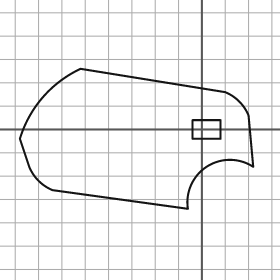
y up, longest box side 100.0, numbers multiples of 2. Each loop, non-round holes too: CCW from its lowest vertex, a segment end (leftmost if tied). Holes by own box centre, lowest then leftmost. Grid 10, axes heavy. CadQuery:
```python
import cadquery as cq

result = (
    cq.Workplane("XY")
    .moveTo(-6.0, -34.0)
    .threePointArc((2.0, -16.0), (22.0, -16.0))
    .lineTo(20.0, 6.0)
    .threePointArc((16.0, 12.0), (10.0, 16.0))
    .lineTo(-52.0, 26.0)
    .threePointArc((-68.0, 14.0), (-78.0, -4.0))
    .lineTo(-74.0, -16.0)
    .threePointArc((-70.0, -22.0), (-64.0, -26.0))
    .close()
    .moveTo(-4.0, -4.0)
    .lineTo(8.0, -4.0)
    .lineTo(8.0, 4.0)
    .lineTo(-4.0, 4.0)
    .close()
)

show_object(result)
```